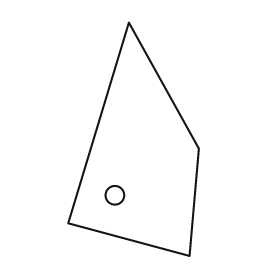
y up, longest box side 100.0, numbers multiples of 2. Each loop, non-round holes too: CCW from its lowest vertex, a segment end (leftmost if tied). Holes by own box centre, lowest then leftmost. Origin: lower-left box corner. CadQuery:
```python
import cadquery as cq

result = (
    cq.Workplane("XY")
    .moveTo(52.0, 0.0)
    .lineTo(56.0, 46.0)
    .lineTo(26.0, 100.0)
    .lineTo(0.0, 14.0)
    .close()
    .moveTo(20.0, 26.0)
    .circle(4.0)
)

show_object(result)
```